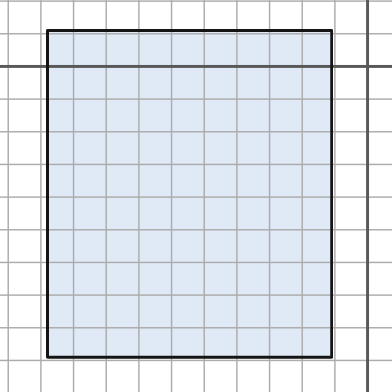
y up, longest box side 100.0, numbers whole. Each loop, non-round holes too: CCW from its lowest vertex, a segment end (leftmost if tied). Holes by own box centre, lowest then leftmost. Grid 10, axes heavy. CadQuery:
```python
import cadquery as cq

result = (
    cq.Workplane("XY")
    .moveTo(-98.0, -89.0)
    .lineTo(-11.0, -89.0)
    .lineTo(-11.0, 11.0)
    .lineTo(-98.0, 11.0)
    .close()
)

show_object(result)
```